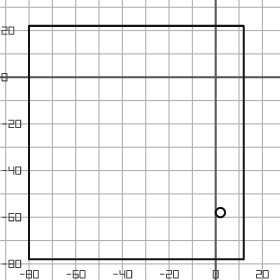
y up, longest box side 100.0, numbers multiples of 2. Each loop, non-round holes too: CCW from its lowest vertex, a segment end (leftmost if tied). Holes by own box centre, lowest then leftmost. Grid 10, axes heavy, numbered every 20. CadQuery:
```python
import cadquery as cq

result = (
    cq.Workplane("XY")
    .moveTo(-80.0, -78.0)
    .lineTo(12.0, -78.0)
    .lineTo(12.0, 22.0)
    .lineTo(-80.0, 22.0)
    .close()
    .moveTo(2.0, -58.0)
    .circle(2.0)
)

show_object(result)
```